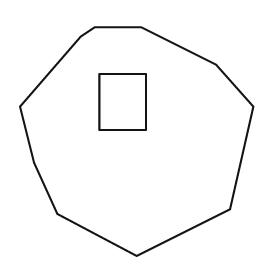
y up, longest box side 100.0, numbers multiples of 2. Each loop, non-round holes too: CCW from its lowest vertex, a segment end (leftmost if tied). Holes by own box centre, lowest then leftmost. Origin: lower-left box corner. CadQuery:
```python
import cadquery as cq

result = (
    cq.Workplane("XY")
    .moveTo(50.0, 0.0)
    .lineTo(90.0, 20.0)
    .lineTo(100.0, 64.0)
    .lineTo(84.0, 82.0)
    .lineTo(52.0, 98.0)
    .lineTo(32.0, 98.0)
    .lineTo(26.0, 94.0)
    .lineTo(0.0, 64.0)
    .lineTo(6.0, 40.0)
    .lineTo(16.0, 18.0)
    .close()
    .moveTo(34.0, 54.0)
    .lineTo(54.0, 54.0)
    .lineTo(54.0, 78.0)
    .lineTo(34.0, 78.0)
    .close()
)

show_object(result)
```